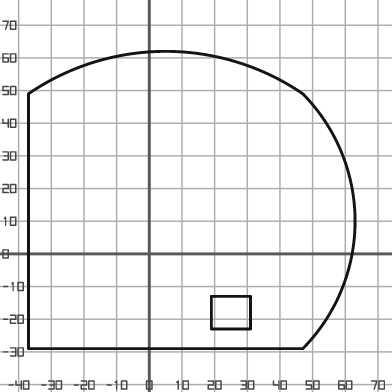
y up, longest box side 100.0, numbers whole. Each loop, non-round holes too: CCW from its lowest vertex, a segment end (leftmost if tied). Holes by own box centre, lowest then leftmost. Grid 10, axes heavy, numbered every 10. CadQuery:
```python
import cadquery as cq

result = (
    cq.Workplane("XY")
    .moveTo(-37.0, -29.0)
    .lineTo(47.0, -29.0)
    .threePointArc((63.0, 10.0), (47.0, 49.0))
    .threePointArc((5.0, 62.0), (-37.0, 49.0))
    .close()
    .moveTo(19.0, -23.0)
    .lineTo(31.0, -23.0)
    .lineTo(31.0, -13.0)
    .lineTo(19.0, -13.0)
    .close()
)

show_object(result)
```